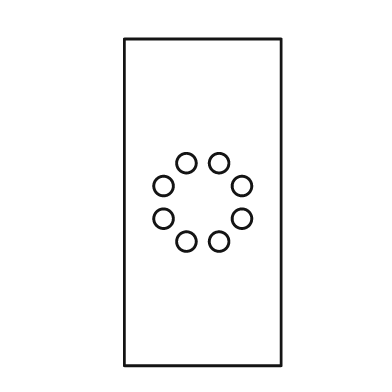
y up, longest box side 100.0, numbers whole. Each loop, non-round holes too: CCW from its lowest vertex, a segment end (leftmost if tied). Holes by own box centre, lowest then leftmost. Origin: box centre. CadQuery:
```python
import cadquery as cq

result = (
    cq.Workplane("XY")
    .moveTo(-24.0, -50.0)
    .lineTo(24.0, -50.0)
    .lineTo(24.0, 50.0)
    .lineTo(-24.0, 50.0)
    .close()
    .moveTo(-5.0, -12.0)
    .circle(3.0)
    .moveTo(5.0, -12.0)
    .circle(3.0)
    .moveTo(-12.0, -5.0)
    .circle(3.0)
    .moveTo(12.0, -5.0)
    .circle(3.0)
    .moveTo(-12.0, 5.0)
    .circle(3.0)
    .moveTo(12.0, 5.0)
    .circle(3.0)
    .moveTo(-5.0, 12.0)
    .circle(3.0)
    .moveTo(5.0, 12.0)
    .circle(3.0)
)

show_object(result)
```